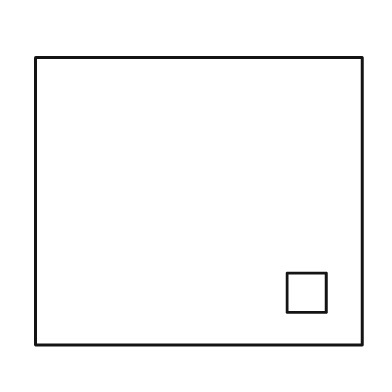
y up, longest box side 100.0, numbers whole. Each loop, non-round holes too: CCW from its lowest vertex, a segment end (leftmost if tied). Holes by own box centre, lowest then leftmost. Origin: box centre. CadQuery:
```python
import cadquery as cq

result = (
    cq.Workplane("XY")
    .moveTo(-50.0, -44.0)
    .lineTo(50.0, -44.0)
    .lineTo(50.0, 44.0)
    .lineTo(-50.0, 44.0)
    .close()
    .moveTo(27.0, -34.0)
    .lineTo(39.0, -34.0)
    .lineTo(39.0, -22.0)
    .lineTo(27.0, -22.0)
    .close()
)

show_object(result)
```